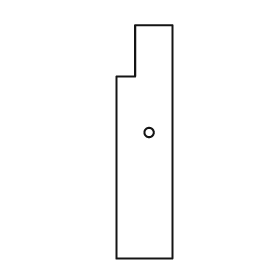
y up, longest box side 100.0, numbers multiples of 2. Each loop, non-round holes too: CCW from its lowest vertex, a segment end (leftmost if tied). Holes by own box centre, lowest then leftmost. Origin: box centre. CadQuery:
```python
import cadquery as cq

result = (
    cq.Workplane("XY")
    .moveTo(-12.0, -50.0)
    .lineTo(12.0, -50.0)
    .lineTo(12.0, 50.0)
    .lineTo(-4.0, 50.0)
    .lineTo(-4.0, 28.0)
    .lineTo(-12.0, 28.0)
    .close()
    .moveTo(2.0, 4.0)
    .circle(2.0)
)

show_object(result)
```